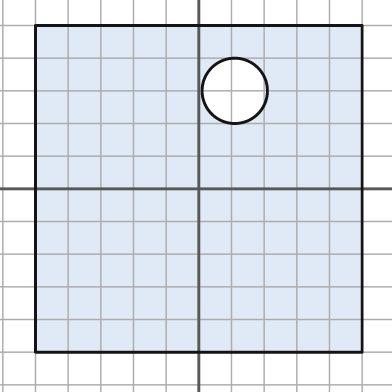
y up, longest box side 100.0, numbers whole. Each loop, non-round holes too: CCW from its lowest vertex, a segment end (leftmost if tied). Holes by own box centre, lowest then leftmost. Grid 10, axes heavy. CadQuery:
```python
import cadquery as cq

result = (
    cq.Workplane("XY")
    .moveTo(-50.0, -50.0)
    .lineTo(50.0, -50.0)
    .lineTo(50.0, 50.0)
    .lineTo(-50.0, 50.0)
    .close()
    .moveTo(11.0, 30.0)
    .circle(10.0)
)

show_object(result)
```